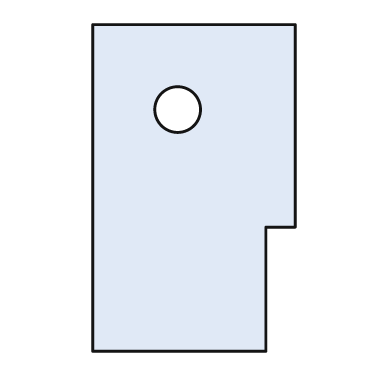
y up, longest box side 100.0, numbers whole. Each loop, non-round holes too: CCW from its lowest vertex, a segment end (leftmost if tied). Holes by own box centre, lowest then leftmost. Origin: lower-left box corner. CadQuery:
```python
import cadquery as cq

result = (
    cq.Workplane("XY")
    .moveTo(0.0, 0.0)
    .lineTo(53.0, 0.0)
    .lineTo(53.0, 38.0)
    .lineTo(62.0, 38.0)
    .lineTo(62.0, 100.0)
    .lineTo(0.0, 100.0)
    .close()
    .moveTo(26.0, 74.0)
    .circle(7.0)
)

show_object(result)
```